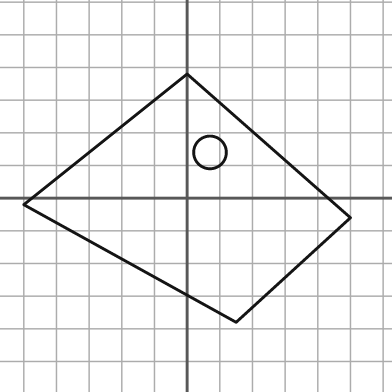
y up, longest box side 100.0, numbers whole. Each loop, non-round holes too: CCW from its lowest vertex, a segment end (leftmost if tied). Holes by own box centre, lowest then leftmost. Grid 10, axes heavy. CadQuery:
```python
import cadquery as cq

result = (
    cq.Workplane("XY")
    .moveTo(15.0, -38.0)
    .lineTo(50.0, -6.0)
    .lineTo(0.0, 38.0)
    .lineTo(-50.0, -2.0)
    .close()
    .moveTo(7.0, 14.0)
    .circle(5.0)
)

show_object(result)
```